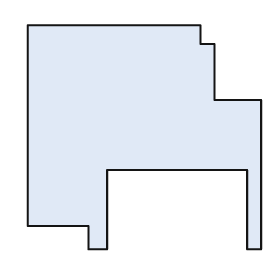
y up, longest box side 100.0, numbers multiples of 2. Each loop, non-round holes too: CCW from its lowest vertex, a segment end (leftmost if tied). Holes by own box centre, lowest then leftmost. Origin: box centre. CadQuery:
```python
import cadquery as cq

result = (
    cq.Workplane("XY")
    .moveTo(-24.0, -48.0)
    .lineTo(-16.0, -48.0)
    .lineTo(-16.0, -14.0)
    .lineTo(44.0, -14.0)
    .lineTo(44.0, -48.0)
    .lineTo(50.0, -48.0)
    .lineTo(50.0, 16.0)
    .lineTo(30.0, 16.0)
    .lineTo(30.0, 40.0)
    .lineTo(24.0, 40.0)
    .lineTo(24.0, 48.0)
    .lineTo(-50.0, 48.0)
    .lineTo(-50.0, -38.0)
    .lineTo(-24.0, -38.0)
    .close()
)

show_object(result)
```